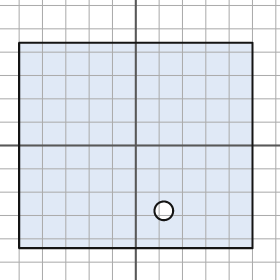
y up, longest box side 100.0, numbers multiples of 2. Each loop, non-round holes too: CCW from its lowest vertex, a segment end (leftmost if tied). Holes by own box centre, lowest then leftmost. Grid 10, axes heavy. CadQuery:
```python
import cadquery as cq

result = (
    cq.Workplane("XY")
    .moveTo(-50.0, -44.0)
    .lineTo(50.0, -44.0)
    .lineTo(50.0, 44.0)
    .lineTo(-50.0, 44.0)
    .close()
    .moveTo(12.0, -28.0)
    .circle(4.0)
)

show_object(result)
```